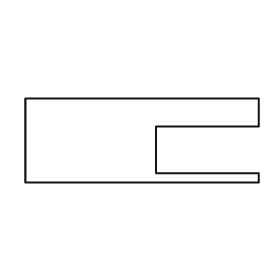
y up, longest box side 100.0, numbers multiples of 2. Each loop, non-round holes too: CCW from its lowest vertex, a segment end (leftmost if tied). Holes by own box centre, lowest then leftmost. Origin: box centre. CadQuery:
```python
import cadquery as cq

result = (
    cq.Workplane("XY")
    .moveTo(-50.0, -18.0)
    .lineTo(50.0, -18.0)
    .lineTo(50.0, -14.0)
    .lineTo(6.0, -14.0)
    .lineTo(6.0, 6.0)
    .lineTo(50.0, 6.0)
    .lineTo(50.0, 18.0)
    .lineTo(-50.0, 18.0)
    .close()
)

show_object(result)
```